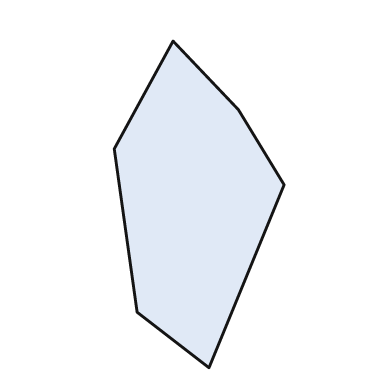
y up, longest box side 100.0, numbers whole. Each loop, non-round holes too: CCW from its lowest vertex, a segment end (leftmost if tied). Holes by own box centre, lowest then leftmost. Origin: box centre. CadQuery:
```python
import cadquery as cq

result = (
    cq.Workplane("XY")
    .moveTo(3.0, -50.0)
    .lineTo(26.0, 6.0)
    .lineTo(12.0, 29.0)
    .lineTo(-8.0, 50.0)
    .lineTo(-26.0, 17.0)
    .lineTo(-19.0, -33.0)
    .close()
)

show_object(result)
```